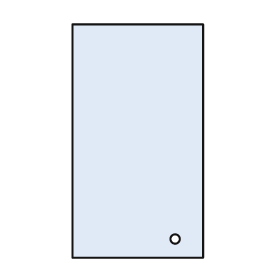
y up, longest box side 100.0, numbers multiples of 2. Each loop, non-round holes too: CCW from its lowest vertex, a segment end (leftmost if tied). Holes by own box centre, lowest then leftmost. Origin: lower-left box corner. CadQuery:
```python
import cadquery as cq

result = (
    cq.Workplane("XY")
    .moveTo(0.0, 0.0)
    .lineTo(56.0, 0.0)
    .lineTo(56.0, 100.0)
    .lineTo(0.0, 100.0)
    .close()
    .moveTo(44.0, 8.0)
    .circle(2.0)
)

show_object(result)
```